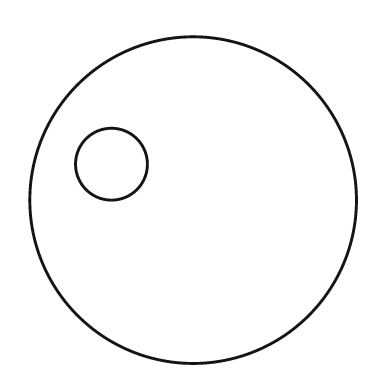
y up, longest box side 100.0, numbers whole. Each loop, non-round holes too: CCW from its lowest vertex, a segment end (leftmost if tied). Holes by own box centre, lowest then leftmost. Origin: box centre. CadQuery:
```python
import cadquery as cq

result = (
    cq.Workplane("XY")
    .moveTo(0.0, 0.0)
    .circle(50.0)
    .moveTo(-25.0, 11.0)
    .circle(11.0)
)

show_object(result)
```